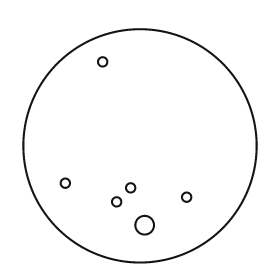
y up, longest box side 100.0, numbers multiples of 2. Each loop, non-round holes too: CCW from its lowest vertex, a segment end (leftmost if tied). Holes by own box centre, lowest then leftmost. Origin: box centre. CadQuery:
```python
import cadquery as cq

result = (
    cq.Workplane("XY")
    .moveTo(0.0, 0.0)
    .circle(50.0)
    .moveTo(2.0, -34.0)
    .circle(4.0)
    .moveTo(-10.0, -24.0)
    .circle(2.0)
    .moveTo(20.0, -22.0)
    .circle(2.0)
    .moveTo(-4.0, -18.0)
    .circle(2.0)
    .moveTo(-32.0, -16.0)
    .circle(2.0)
    .moveTo(-16.0, 36.0)
    .circle(2.0)
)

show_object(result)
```